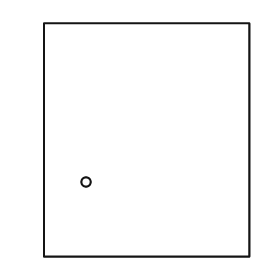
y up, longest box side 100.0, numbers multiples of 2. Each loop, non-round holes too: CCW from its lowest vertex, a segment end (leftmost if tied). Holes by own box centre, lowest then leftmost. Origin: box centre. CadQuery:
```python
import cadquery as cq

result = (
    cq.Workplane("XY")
    .moveTo(-44.0, -50.0)
    .lineTo(44.0, -50.0)
    .lineTo(44.0, 50.0)
    .lineTo(-44.0, 50.0)
    .close()
    .moveTo(-26.0, -18.0)
    .circle(2.0)
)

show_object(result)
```